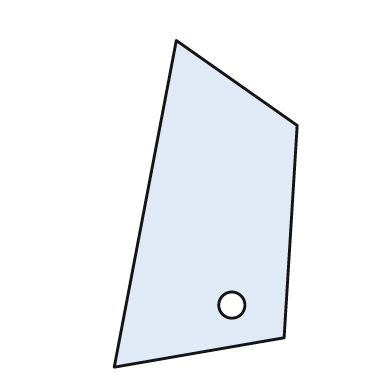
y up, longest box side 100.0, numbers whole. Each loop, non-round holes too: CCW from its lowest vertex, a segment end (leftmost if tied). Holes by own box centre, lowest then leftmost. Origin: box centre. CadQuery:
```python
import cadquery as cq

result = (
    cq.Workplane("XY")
    .moveTo(-28.0, -50.0)
    .lineTo(24.0, -41.0)
    .lineTo(28.0, 24.0)
    .lineTo(-9.0, 50.0)
    .close()
    .moveTo(8.0, -31.0)
    .circle(4.0)
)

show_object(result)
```